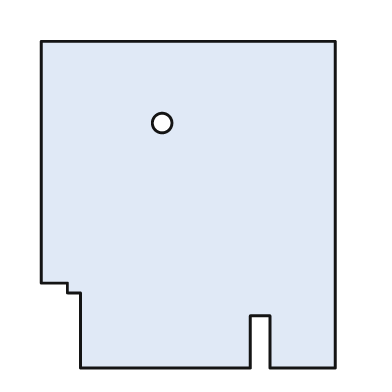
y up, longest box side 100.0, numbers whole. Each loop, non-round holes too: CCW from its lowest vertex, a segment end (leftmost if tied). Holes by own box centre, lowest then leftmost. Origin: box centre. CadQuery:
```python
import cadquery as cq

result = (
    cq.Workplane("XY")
    .moveTo(-33.0, -50.0)
    .lineTo(19.0, -50.0)
    .lineTo(19.0, -34.0)
    .lineTo(25.0, -34.0)
    .lineTo(25.0, -50.0)
    .lineTo(45.0, -50.0)
    .lineTo(45.0, 50.0)
    .lineTo(-45.0, 50.0)
    .lineTo(-45.0, -24.0)
    .lineTo(-37.0, -24.0)
    .lineTo(-37.0, -27.0)
    .lineTo(-33.0, -27.0)
    .close()
    .moveTo(-8.0, 25.0)
    .circle(3.0)
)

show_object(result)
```